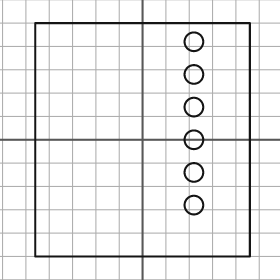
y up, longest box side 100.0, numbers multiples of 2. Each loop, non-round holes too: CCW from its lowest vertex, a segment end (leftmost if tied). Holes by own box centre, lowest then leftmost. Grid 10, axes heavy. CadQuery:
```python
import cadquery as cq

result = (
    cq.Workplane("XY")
    .moveTo(-46.0, -50.0)
    .lineTo(46.0, -50.0)
    .lineTo(46.0, 50.0)
    .lineTo(-46.0, 50.0)
    .close()
    .moveTo(22.0, -28.0)
    .circle(4.0)
    .moveTo(22.0, -14.0)
    .circle(4.0)
    .moveTo(22.0, 0.0)
    .circle(4.0)
    .moveTo(22.0, 14.0)
    .circle(4.0)
    .moveTo(22.0, 28.0)
    .circle(4.0)
    .moveTo(22.0, 42.0)
    .circle(4.0)
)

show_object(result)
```